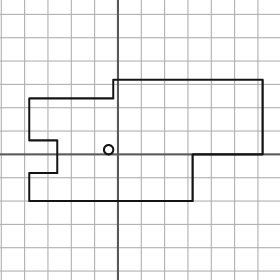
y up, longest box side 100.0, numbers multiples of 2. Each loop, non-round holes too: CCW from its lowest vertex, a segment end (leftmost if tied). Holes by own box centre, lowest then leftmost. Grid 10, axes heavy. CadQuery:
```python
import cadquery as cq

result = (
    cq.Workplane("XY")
    .moveTo(-38.0, -20.0)
    .lineTo(32.0, -20.0)
    .lineTo(32.0, 0.0)
    .lineTo(62.0, 0.0)
    .lineTo(62.0, 32.0)
    .lineTo(-2.0, 32.0)
    .lineTo(-2.0, 24.0)
    .lineTo(-38.0, 24.0)
    .lineTo(-38.0, 6.0)
    .lineTo(-26.0, 6.0)
    .lineTo(-26.0, -8.0)
    .lineTo(-38.0, -8.0)
    .close()
    .moveTo(-4.0, 2.0)
    .circle(2.0)
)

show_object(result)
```